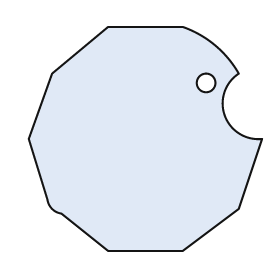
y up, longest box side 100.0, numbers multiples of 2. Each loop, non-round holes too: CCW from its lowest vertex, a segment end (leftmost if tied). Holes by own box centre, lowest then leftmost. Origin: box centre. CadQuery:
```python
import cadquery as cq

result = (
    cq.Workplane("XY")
    .moveTo(-16.0, -48.0)
    .lineTo(16.0, -48.0)
    .lineTo(40.0, -30.0)
    .lineTo(50.0, 0.0)
    .threePointArc((34.0, 10.0), (40.0, 28.0))
    .threePointArc((30.0, 40.0), (16.0, 48.0))
    .lineTo(-16.0, 48.0)
    .lineTo(-40.0, 28.0)
    .lineTo(-50.0, 0.0)
    .lineTo(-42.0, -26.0)
    .threePointArc((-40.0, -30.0), (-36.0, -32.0))
    .close()
    .moveTo(26.0, 24.0)
    .circle(4.0)
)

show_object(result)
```